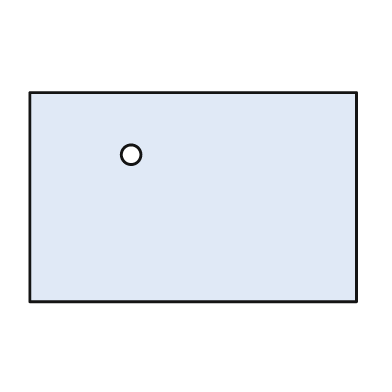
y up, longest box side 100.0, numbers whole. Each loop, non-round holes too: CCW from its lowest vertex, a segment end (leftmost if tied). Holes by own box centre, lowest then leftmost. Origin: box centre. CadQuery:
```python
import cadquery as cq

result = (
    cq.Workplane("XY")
    .moveTo(-50.0, -32.0)
    .lineTo(50.0, -32.0)
    .lineTo(50.0, 32.0)
    .lineTo(-50.0, 32.0)
    .close()
    .moveTo(-19.0, 13.0)
    .circle(3.0)
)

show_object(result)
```